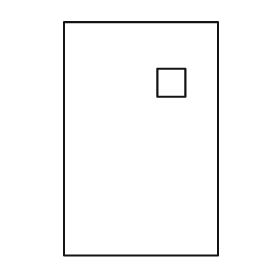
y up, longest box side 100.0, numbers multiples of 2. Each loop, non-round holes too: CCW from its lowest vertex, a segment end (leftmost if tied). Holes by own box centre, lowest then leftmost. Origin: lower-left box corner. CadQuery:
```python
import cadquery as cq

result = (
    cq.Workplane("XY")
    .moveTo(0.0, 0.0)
    .lineTo(66.0, 0.0)
    .lineTo(66.0, 100.0)
    .lineTo(0.0, 100.0)
    .close()
    .moveTo(40.0, 68.0)
    .lineTo(52.0, 68.0)
    .lineTo(52.0, 80.0)
    .lineTo(40.0, 80.0)
    .close()
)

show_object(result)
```